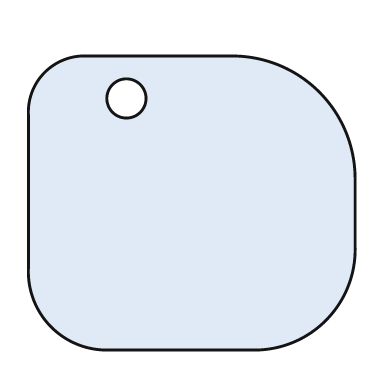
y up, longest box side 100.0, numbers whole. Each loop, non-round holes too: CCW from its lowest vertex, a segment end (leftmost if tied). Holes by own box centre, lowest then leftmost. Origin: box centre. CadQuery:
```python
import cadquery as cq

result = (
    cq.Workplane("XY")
    .moveTo(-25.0, -45.0)
    .lineTo(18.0, -45.0)
    .threePointArc((41.0, -36.0), (50.0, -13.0))
    .lineTo(50.0, 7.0)
    .threePointArc((39.0, 34.0), (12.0, 45.0))
    .lineTo(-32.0, 45.0)
    .threePointArc((-45.0, 40.0), (-50.0, 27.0))
    .lineTo(-50.0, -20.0)
    .threePointArc((-43.0, -38.0), (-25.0, -45.0))
    .close()
    .moveTo(-20.0, 32.0)
    .circle(6.0)
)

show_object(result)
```